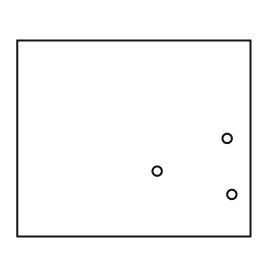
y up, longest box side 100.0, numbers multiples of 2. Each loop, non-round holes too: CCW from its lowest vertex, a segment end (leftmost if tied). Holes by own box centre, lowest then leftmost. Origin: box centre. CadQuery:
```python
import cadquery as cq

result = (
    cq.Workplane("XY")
    .moveTo(-50.0, -42.0)
    .lineTo(50.0, -42.0)
    .lineTo(50.0, 42.0)
    .lineTo(-50.0, 42.0)
    .close()
    .moveTo(42.0, -24.0)
    .circle(2.0)
    .moveTo(10.0, -14.0)
    .circle(2.0)
    .moveTo(40.0, 0.0)
    .circle(2.0)
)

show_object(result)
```